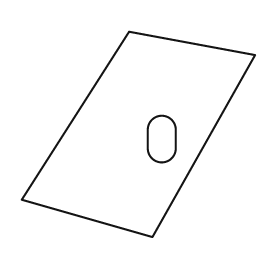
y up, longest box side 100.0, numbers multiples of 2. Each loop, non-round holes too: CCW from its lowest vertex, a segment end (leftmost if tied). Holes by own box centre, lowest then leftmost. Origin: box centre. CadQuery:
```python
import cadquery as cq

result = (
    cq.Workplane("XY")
    .moveTo(6.0, -44.0)
    .lineTo(50.0, 34.0)
    .lineTo(-4.0, 44.0)
    .lineTo(-50.0, -28.0)
    .close()
    .moveTo(4.0, -6.0)
    .threePointArc((10.0, -12.0), (16.0, -6.0))
    .lineTo(16.0, 2.0)
    .threePointArc((10.0, 8.0), (4.0, 2.0))
    .close()
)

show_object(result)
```